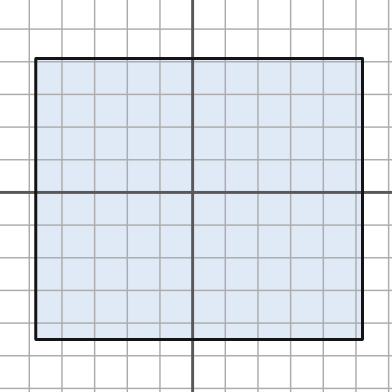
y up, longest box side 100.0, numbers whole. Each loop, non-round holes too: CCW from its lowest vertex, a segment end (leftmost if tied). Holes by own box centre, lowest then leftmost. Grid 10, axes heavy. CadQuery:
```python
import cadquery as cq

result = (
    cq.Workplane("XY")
    .moveTo(-48.0, -45.0)
    .lineTo(52.0, -45.0)
    .lineTo(52.0, 41.0)
    .lineTo(-48.0, 41.0)
    .close()
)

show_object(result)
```